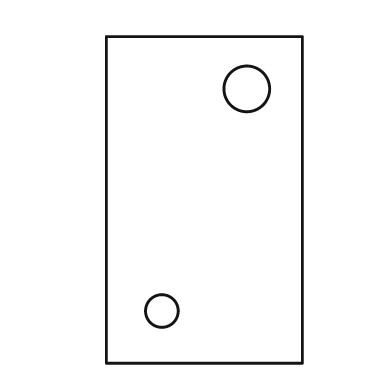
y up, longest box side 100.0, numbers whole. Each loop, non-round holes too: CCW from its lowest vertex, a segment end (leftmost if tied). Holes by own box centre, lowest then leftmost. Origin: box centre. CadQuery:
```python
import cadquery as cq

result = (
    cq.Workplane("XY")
    .moveTo(-30.0, -50.0)
    .lineTo(30.0, -50.0)
    .lineTo(30.0, 50.0)
    .lineTo(-30.0, 50.0)
    .close()
    .moveTo(-13.0, -34.0)
    .circle(5.0)
    .moveTo(13.0, 34.0)
    .circle(7.0)
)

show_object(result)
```